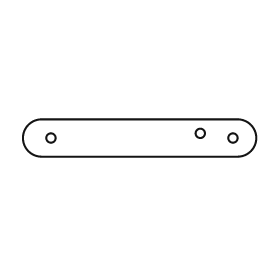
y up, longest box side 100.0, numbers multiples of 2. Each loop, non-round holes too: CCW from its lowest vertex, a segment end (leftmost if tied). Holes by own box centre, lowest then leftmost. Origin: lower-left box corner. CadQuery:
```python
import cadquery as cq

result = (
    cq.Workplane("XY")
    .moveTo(8.0, 0.0)
    .lineTo(92.0, 0.0)
    .threePointArc((100.0, 8.0), (92.0, 16.0))
    .lineTo(8.0, 16.0)
    .threePointArc((0.0, 8.0), (8.0, 0.0))
    .close()
    .moveTo(12.0, 8.0)
    .circle(2.0)
    .moveTo(90.0, 8.0)
    .circle(2.0)
    .moveTo(76.0, 10.0)
    .circle(2.0)
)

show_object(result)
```